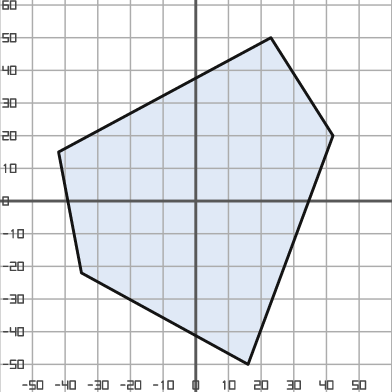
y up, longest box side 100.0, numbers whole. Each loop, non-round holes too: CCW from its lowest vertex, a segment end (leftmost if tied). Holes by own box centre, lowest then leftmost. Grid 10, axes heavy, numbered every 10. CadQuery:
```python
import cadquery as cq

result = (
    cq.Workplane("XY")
    .moveTo(16.0, -50.0)
    .lineTo(42.0, 20.0)
    .lineTo(23.0, 50.0)
    .lineTo(-42.0, 15.0)
    .lineTo(-35.0, -22.0)
    .close()
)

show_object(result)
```